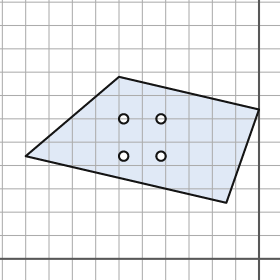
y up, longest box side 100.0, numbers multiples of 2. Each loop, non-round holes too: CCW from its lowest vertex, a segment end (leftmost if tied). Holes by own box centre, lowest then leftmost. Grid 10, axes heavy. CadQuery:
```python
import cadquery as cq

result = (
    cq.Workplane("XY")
    .moveTo(-14.0, 24.0)
    .lineTo(0.0, 64.0)
    .lineTo(-60.0, 78.0)
    .lineTo(-100.0, 44.0)
    .close()
    .moveTo(-58.0, 44.0)
    .circle(2.0)
    .moveTo(-42.0, 44.0)
    .circle(2.0)
    .moveTo(-58.0, 60.0)
    .circle(2.0)
    .moveTo(-42.0, 60.0)
    .circle(2.0)
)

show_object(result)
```